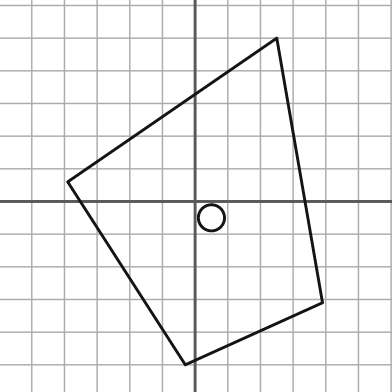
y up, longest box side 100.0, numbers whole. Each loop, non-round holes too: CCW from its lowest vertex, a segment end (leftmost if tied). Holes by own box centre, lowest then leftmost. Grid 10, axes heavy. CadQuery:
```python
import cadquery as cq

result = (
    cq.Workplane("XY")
    .moveTo(-3.0, -50.0)
    .lineTo(39.0, -31.0)
    .lineTo(25.0, 50.0)
    .lineTo(-39.0, 6.0)
    .close()
    .moveTo(5.0, -5.0)
    .circle(4.0)
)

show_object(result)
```